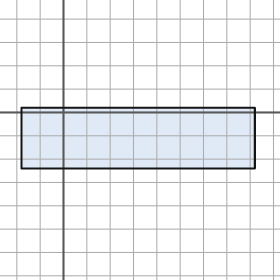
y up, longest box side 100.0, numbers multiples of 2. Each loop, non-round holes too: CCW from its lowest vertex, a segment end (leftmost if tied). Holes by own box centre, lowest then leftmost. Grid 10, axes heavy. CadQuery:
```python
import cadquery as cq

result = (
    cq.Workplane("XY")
    .moveTo(-18.0, -24.0)
    .lineTo(82.0, -24.0)
    .lineTo(82.0, 2.0)
    .lineTo(-18.0, 2.0)
    .close()
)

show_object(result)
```